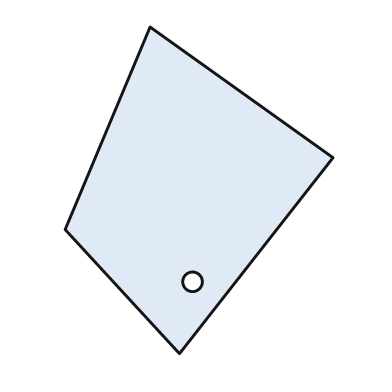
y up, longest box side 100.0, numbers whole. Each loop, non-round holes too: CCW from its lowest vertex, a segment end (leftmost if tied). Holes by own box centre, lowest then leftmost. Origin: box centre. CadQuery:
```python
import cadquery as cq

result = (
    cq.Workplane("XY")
    .moveTo(-6.0, -50.0)
    .lineTo(41.0, 10.0)
    .lineTo(-15.0, 50.0)
    .lineTo(-41.0, -12.0)
    .close()
    .moveTo(-2.0, -28.0)
    .circle(3.0)
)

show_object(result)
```